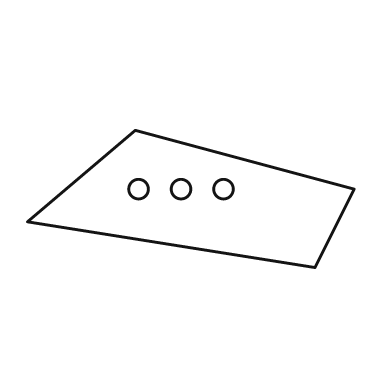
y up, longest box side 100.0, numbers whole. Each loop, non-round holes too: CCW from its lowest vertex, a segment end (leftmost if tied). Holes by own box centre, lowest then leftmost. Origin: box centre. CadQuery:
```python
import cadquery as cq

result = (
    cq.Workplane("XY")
    .moveTo(38.0, -21.0)
    .lineTo(50.0, 3.0)
    .lineTo(-17.0, 21.0)
    .lineTo(-50.0, -7.0)
    .close()
    .moveTo(-16.0, 3.0)
    .circle(3.0)
    .moveTo(-3.0, 3.0)
    .circle(3.0)
    .moveTo(10.0, 3.0)
    .circle(3.0)
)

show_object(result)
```